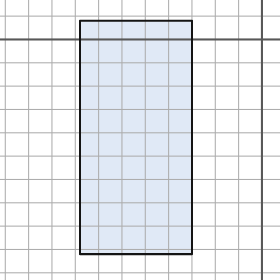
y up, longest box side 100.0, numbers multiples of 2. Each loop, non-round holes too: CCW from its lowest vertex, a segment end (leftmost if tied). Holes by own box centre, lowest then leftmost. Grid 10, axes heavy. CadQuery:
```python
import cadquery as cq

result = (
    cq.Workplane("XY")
    .moveTo(-78.0, -92.0)
    .lineTo(-30.0, -92.0)
    .lineTo(-30.0, 8.0)
    .lineTo(-78.0, 8.0)
    .close()
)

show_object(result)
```